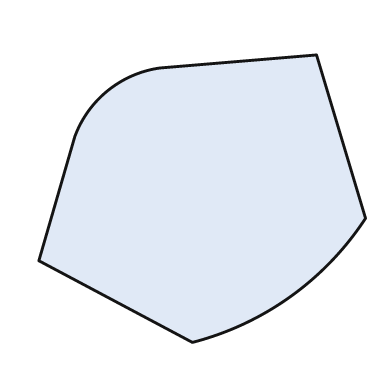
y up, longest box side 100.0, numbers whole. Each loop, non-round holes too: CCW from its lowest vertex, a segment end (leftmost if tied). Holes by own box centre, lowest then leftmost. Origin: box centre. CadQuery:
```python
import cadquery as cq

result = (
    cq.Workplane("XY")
    .moveTo(-3.0, -44.0)
    .threePointArc((27.0, -30.0), (50.0, -6.0))
    .lineTo(35.0, 44.0)
    .lineTo(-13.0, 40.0)
    .threePointArc((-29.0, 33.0), (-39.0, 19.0))
    .lineTo(-50.0, -19.0)
    .close()
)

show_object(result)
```